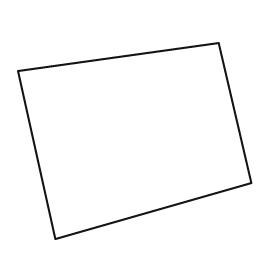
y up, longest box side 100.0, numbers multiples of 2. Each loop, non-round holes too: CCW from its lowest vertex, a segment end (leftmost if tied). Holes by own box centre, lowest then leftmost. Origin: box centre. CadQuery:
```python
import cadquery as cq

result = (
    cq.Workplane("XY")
    .moveTo(-34.0, -42.0)
    .lineTo(50.0, -18.0)
    .lineTo(36.0, 42.0)
    .lineTo(-50.0, 30.0)
    .close()
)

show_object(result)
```